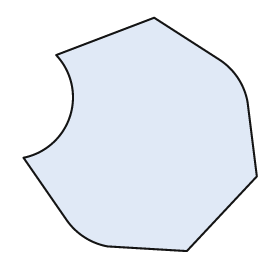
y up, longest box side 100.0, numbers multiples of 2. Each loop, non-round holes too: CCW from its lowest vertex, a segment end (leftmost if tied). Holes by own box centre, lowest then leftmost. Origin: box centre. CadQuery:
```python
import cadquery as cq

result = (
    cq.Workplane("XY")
    .moveTo(20.0, -50.0)
    .lineTo(50.0, -18.0)
    .lineTo(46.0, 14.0)
    .threePointArc((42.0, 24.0), (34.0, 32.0))
    .lineTo(6.0, 50.0)
    .lineTo(-36.0, 34.0)
    .threePointArc((-30.0, 8.0), (-50.0, -10.0))
    .lineTo(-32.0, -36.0)
    .threePointArc((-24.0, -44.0), (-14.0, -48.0))
    .close()
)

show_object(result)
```